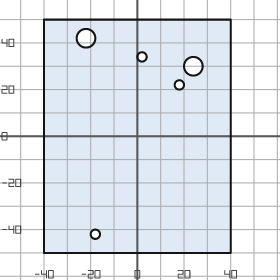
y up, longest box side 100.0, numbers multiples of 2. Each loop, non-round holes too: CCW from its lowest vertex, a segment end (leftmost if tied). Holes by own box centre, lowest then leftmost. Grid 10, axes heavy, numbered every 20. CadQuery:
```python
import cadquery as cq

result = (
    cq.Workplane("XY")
    .moveTo(-40.0, -50.0)
    .lineTo(40.0, -50.0)
    .lineTo(40.0, 50.0)
    .lineTo(-40.0, 50.0)
    .close()
    .moveTo(-18.0, -42.0)
    .circle(2.0)
    .moveTo(18.0, 22.0)
    .circle(2.0)
    .moveTo(24.0, 30.0)
    .circle(4.0)
    .moveTo(2.0, 34.0)
    .circle(2.0)
    .moveTo(-22.0, 42.0)
    .circle(4.0)
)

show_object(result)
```